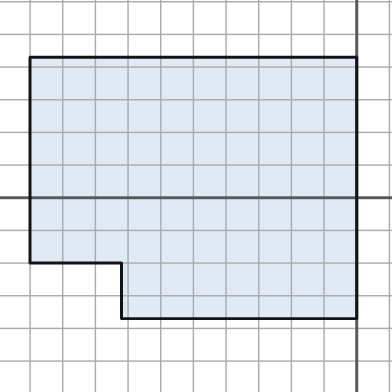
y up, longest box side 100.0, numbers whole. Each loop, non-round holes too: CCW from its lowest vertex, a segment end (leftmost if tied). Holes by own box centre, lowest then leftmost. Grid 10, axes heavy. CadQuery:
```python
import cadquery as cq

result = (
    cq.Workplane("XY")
    .moveTo(-72.0, -37.0)
    .lineTo(0.0, -37.0)
    .lineTo(0.0, 43.0)
    .lineTo(-100.0, 43.0)
    .lineTo(-100.0, -20.0)
    .lineTo(-72.0, -20.0)
    .close()
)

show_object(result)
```